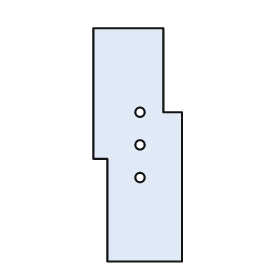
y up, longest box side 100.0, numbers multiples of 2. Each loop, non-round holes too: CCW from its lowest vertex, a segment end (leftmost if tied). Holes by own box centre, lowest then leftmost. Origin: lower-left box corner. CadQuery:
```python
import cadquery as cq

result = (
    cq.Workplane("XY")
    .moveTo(6.0, 0.0)
    .lineTo(38.0, 0.0)
    .lineTo(38.0, 64.0)
    .lineTo(30.0, 64.0)
    .lineTo(30.0, 100.0)
    .lineTo(0.0, 100.0)
    .lineTo(0.0, 44.0)
    .lineTo(6.0, 44.0)
    .close()
    .moveTo(20.0, 36.0)
    .circle(2.0)
    .moveTo(20.0, 50.0)
    .circle(2.0)
    .moveTo(20.0, 64.0)
    .circle(2.0)
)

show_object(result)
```